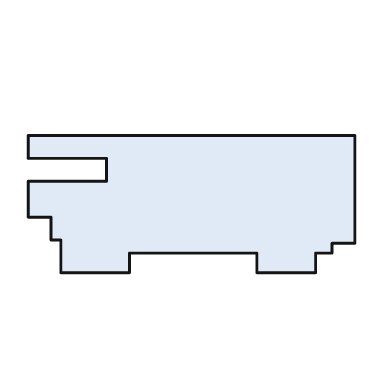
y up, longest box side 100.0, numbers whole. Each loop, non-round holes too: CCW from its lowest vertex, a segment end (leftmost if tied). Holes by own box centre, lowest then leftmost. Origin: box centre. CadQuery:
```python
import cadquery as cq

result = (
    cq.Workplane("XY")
    .moveTo(-40.0, -21.0)
    .lineTo(-19.0, -21.0)
    .lineTo(-19.0, -15.0)
    .lineTo(20.0, -15.0)
    .lineTo(20.0, -21.0)
    .lineTo(38.0, -21.0)
    .lineTo(38.0, -15.0)
    .lineTo(43.0, -15.0)
    .lineTo(43.0, -12.0)
    .lineTo(50.0, -12.0)
    .lineTo(50.0, 21.0)
    .lineTo(-50.0, 21.0)
    .lineTo(-50.0, 14.0)
    .lineTo(-26.0, 14.0)
    .lineTo(-26.0, 7.0)
    .lineTo(-50.0, 7.0)
    .lineTo(-50.0, -4.0)
    .lineTo(-43.0, -4.0)
    .lineTo(-43.0, -11.0)
    .lineTo(-40.0, -11.0)
    .close()
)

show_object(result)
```